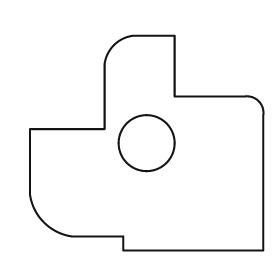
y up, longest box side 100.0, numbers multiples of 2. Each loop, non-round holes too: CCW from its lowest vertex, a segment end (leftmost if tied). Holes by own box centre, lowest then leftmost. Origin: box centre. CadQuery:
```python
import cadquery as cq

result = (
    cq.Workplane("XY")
    .moveTo(-10.0, -46.0)
    .lineTo(50.0, -46.0)
    .lineTo(50.0, 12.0)
    .threePointArc((48.0, 18.0), (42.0, 20.0))
    .lineTo(12.0, 20.0)
    .lineTo(12.0, 46.0)
    .lineTo(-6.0, 46.0)
    .threePointArc((-14.0, 42.0), (-18.0, 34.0))
    .lineTo(-18.0, 6.0)
    .lineTo(-50.0, 6.0)
    .lineTo(-50.0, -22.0)
    .threePointArc((-44.0, -34.0), (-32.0, -40.0))
    .lineTo(-10.0, -40.0)
    .close()
    .moveTo(0.0, 0.0)
    .circle(12.0)
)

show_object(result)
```